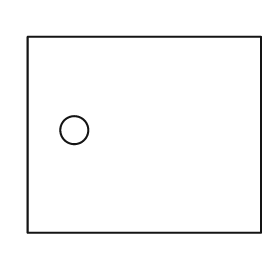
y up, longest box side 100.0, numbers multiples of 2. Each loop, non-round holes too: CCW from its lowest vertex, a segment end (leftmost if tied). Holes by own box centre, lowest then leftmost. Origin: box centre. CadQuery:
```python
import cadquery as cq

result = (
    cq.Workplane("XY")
    .moveTo(-50.0, -42.0)
    .lineTo(50.0, -42.0)
    .lineTo(50.0, 42.0)
    .lineTo(-50.0, 42.0)
    .close()
    .moveTo(-30.0, 2.0)
    .circle(6.0)
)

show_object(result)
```